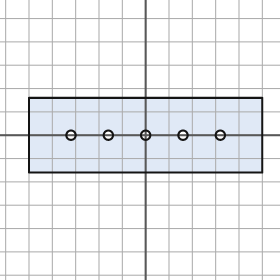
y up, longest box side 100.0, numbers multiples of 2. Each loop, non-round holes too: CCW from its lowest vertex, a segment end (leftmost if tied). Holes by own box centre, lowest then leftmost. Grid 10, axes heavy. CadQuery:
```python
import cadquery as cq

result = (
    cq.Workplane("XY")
    .moveTo(-50.0, -16.0)
    .lineTo(50.0, -16.0)
    .lineTo(50.0, 16.0)
    .lineTo(-50.0, 16.0)
    .close()
    .moveTo(-32.0, 0.0)
    .circle(2.0)
    .moveTo(-16.0, 0.0)
    .circle(2.0)
    .moveTo(0.0, 0.0)
    .circle(2.0)
    .moveTo(16.0, 0.0)
    .circle(2.0)
    .moveTo(32.0, 0.0)
    .circle(2.0)
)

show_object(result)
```